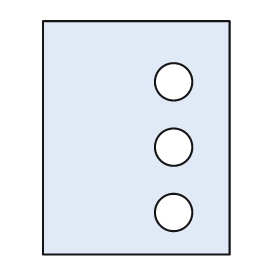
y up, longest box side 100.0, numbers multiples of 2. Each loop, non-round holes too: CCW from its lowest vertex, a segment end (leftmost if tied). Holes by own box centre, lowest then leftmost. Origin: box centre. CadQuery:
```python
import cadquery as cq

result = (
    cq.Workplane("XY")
    .moveTo(-40.0, -50.0)
    .lineTo(40.0, -50.0)
    .lineTo(40.0, 50.0)
    .lineTo(-40.0, 50.0)
    .close()
    .moveTo(16.0, -32.0)
    .circle(8.0)
    .moveTo(16.0, -4.0)
    .circle(8.0)
    .moveTo(16.0, 24.0)
    .circle(8.0)
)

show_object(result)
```